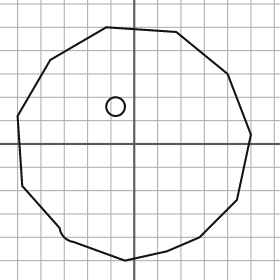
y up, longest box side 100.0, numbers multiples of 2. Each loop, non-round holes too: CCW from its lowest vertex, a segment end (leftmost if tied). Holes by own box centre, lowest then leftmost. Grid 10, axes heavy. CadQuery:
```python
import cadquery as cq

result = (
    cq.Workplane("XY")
    .moveTo(-4.0, -50.0)
    .lineTo(14.0, -46.0)
    .lineTo(28.0, -40.0)
    .lineTo(44.0, -24.0)
    .lineTo(50.0, 4.0)
    .lineTo(40.0, 30.0)
    .lineTo(18.0, 48.0)
    .lineTo(-12.0, 50.0)
    .lineTo(-36.0, 36.0)
    .lineTo(-50.0, 12.0)
    .lineTo(-48.0, -18.0)
    .lineTo(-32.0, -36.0)
    .threePointArc((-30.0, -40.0), (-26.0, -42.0))
    .close()
    .moveTo(-8.0, 16.0)
    .circle(4.0)
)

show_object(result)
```